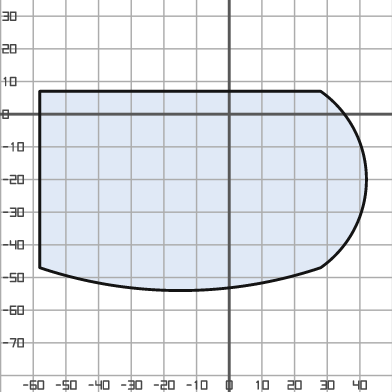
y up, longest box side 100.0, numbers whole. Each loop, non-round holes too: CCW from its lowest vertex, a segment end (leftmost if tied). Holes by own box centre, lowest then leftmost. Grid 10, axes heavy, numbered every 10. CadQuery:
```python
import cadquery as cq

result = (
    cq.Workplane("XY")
    .moveTo(-58.0, -47.0)
    .threePointArc((-15.0, -54.0), (28.0, -47.0))
    .threePointArc((42.0, -20.0), (28.0, 7.0))
    .lineTo(-58.0, 7.0)
    .close()
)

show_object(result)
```